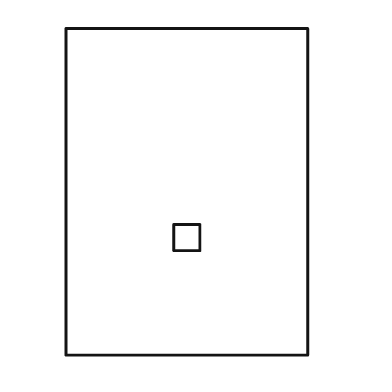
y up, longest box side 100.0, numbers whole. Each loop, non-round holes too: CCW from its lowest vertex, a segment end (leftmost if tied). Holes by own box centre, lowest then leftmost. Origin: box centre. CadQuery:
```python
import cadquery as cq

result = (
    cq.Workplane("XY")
    .moveTo(-37.0, -50.0)
    .lineTo(37.0, -50.0)
    .lineTo(37.0, 50.0)
    .lineTo(-37.0, 50.0)
    .close()
    .moveTo(-4.0, -18.0)
    .lineTo(4.0, -18.0)
    .lineTo(4.0, -10.0)
    .lineTo(-4.0, -10.0)
    .close()
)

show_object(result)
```